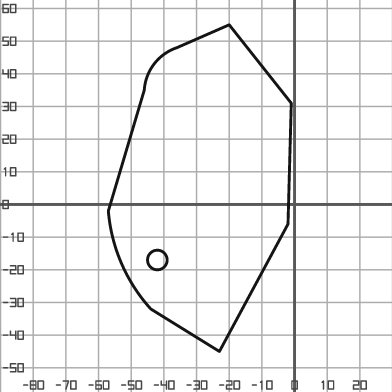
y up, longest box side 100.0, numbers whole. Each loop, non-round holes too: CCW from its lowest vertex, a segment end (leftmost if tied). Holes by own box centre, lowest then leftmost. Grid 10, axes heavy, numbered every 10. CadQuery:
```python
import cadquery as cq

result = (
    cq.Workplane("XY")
    .moveTo(-23.0, -45.0)
    .lineTo(-2.0, -6.0)
    .lineTo(-1.0, 31.0)
    .lineTo(-20.0, 55.0)
    .lineTo(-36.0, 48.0)
    .threePointArc((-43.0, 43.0), (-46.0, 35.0))
    .lineTo(-57.0, -2.0)
    .threePointArc((-53.0, -18.0), (-44.0, -32.0))
    .close()
    .moveTo(-42.0, -17.0)
    .circle(3.0)
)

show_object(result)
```